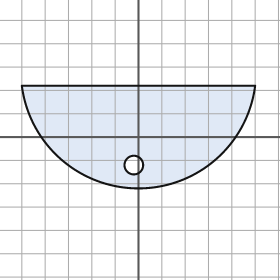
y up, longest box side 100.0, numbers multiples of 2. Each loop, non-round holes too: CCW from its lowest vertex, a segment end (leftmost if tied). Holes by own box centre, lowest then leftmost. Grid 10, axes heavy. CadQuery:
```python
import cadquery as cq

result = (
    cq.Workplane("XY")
    .moveTo(-50.0, 22.0)
    .threePointArc((0.0, -22.0), (50.0, 22.0))
    .close()
    .moveTo(-2.0, -12.0)
    .circle(4.0)
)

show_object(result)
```